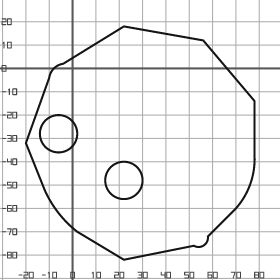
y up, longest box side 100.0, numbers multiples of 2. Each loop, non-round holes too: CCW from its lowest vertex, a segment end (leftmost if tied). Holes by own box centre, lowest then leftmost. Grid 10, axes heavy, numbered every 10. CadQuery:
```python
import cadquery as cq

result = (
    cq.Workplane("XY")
    .moveTo(22.0, -82.0)
    .lineTo(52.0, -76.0)
    .threePointArc((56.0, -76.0), (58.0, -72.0))
    .lineTo(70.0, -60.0)
    .threePointArc((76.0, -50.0), (78.0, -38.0))
    .lineTo(78.0, -14.0)
    .lineTo(56.0, 12.0)
    .lineTo(22.0, 18.0)
    .lineTo(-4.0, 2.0)
    .threePointArc((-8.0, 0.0), (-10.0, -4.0))
    .lineTo(-20.0, -32.0)
    .lineTo(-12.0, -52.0)
    .threePointArc((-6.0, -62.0), (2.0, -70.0))
    .close()
    .moveTo(22.0, -48.0)
    .circle(8.0)
    .moveTo(-6.0, -28.0)
    .circle(8.0)
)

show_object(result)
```